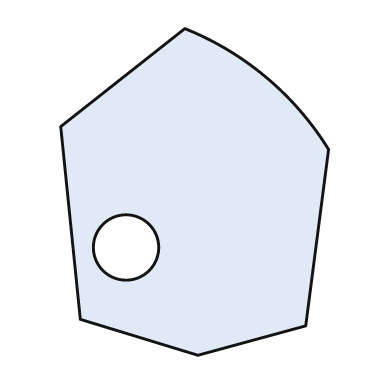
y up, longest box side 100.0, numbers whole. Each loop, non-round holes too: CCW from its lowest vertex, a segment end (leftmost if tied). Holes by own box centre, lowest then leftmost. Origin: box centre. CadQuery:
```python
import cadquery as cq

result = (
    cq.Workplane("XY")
    .moveTo(1.0, -50.0)
    .lineTo(34.0, -41.0)
    .lineTo(41.0, 13.0)
    .threePointArc((22.0, 35.0), (-3.0, 50.0))
    .lineTo(-41.0, 20.0)
    .lineTo(-35.0, -39.0)
    .close()
    .moveTo(-21.0, -17.0)
    .circle(10.0)
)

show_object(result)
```